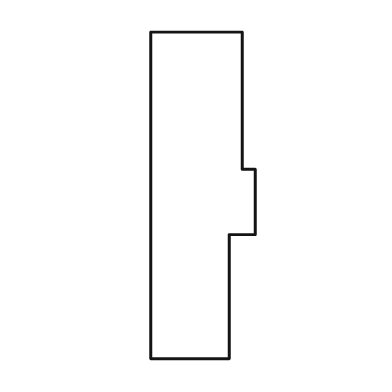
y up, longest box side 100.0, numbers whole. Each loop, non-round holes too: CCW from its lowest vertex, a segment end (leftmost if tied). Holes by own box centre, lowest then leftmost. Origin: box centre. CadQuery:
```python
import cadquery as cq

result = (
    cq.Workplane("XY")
    .moveTo(-16.0, -50.0)
    .lineTo(8.0, -50.0)
    .lineTo(8.0, -12.0)
    .lineTo(16.0, -12.0)
    .lineTo(16.0, 8.0)
    .lineTo(12.0, 8.0)
    .lineTo(12.0, 50.0)
    .lineTo(-16.0, 50.0)
    .close()
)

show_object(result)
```